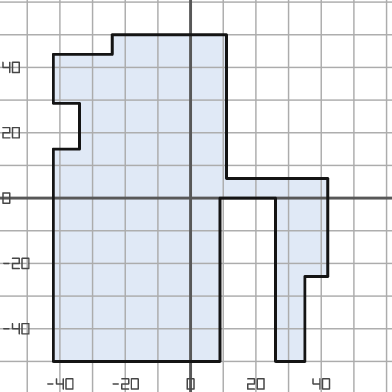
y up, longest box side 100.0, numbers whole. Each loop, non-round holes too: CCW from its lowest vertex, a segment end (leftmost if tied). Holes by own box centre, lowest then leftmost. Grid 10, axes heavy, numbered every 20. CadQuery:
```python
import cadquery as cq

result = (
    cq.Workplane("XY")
    .moveTo(-42.0, -50.0)
    .lineTo(9.0, -50.0)
    .lineTo(9.0, 0.0)
    .lineTo(26.0, 0.0)
    .lineTo(26.0, -50.0)
    .lineTo(35.0, -50.0)
    .lineTo(35.0, -24.0)
    .lineTo(42.0, -24.0)
    .lineTo(42.0, 6.0)
    .lineTo(11.0, 6.0)
    .lineTo(11.0, 50.0)
    .lineTo(-24.0, 50.0)
    .lineTo(-24.0, 44.0)
    .lineTo(-42.0, 44.0)
    .lineTo(-42.0, 29.0)
    .lineTo(-34.0, 29.0)
    .lineTo(-34.0, 15.0)
    .lineTo(-42.0, 15.0)
    .close()
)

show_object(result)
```